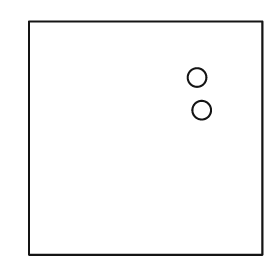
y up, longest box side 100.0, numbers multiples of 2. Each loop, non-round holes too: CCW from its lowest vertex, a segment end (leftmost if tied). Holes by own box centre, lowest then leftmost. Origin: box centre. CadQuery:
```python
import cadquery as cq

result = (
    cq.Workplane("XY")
    .moveTo(-50.0, -50.0)
    .lineTo(50.0, -50.0)
    .lineTo(50.0, 50.0)
    .lineTo(-50.0, 50.0)
    .close()
    .moveTo(24.0, 12.0)
    .circle(4.0)
    .moveTo(22.0, 26.0)
    .circle(4.0)
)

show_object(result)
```